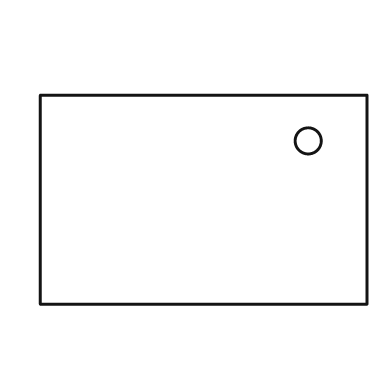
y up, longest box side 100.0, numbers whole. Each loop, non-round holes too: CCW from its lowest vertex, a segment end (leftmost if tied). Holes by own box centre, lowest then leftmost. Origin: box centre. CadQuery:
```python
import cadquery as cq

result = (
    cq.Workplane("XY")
    .moveTo(-50.0, -32.0)
    .lineTo(50.0, -32.0)
    .lineTo(50.0, 32.0)
    .lineTo(-50.0, 32.0)
    .close()
    .moveTo(32.0, 18.0)
    .circle(4.0)
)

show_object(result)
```